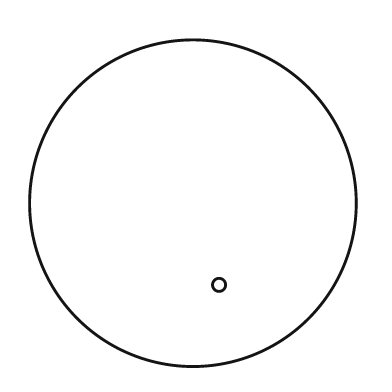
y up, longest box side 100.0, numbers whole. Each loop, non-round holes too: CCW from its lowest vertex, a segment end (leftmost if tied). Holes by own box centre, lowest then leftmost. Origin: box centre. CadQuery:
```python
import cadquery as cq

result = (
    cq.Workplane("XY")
    .moveTo(0.0, 0.0)
    .circle(50.0)
    .moveTo(8.0, -25.0)
    .circle(2.0)
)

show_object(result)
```